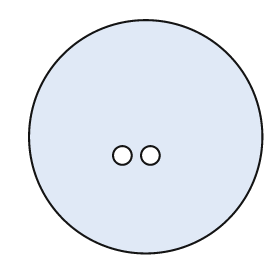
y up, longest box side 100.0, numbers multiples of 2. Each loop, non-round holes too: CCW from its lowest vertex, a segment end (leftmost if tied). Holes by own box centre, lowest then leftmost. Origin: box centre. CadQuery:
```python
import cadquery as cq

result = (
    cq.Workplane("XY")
    .moveTo(0.0, 0.0)
    .circle(50.0)
    .moveTo(-10.0, -8.0)
    .circle(4.0)
    .moveTo(2.0, -8.0)
    .circle(4.0)
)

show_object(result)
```